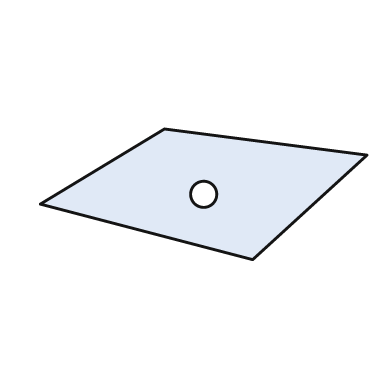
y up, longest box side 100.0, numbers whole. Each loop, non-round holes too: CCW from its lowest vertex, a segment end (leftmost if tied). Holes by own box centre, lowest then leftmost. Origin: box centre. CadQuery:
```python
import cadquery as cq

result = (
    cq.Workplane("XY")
    .moveTo(15.0, -20.0)
    .lineTo(50.0, 12.0)
    .lineTo(-12.0, 20.0)
    .lineTo(-50.0, -3.0)
    .close()
    .moveTo(0.0, 0.0)
    .circle(4.0)
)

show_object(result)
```